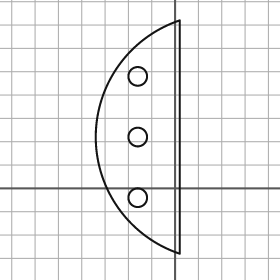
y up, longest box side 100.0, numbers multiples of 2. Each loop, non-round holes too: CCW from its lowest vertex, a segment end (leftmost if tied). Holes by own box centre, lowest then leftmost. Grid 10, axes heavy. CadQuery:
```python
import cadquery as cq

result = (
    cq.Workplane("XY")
    .moveTo(2.0, -28.0)
    .lineTo(2.0, 72.0)
    .threePointArc((-34.0, 22.0), (2.0, -28.0))
    .close()
    .moveTo(-16.0, -4.0)
    .circle(4.0)
    .moveTo(-16.0, 22.0)
    .circle(4.0)
    .moveTo(-16.0, 48.0)
    .circle(4.0)
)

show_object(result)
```